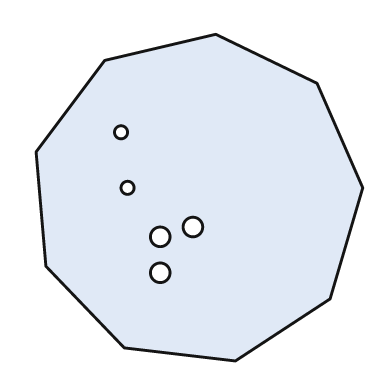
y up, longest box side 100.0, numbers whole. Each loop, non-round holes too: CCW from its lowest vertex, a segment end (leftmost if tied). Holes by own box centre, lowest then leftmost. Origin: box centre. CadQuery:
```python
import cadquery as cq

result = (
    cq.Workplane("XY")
    .moveTo(11.0, -50.0)
    .lineTo(40.0, -31.0)
    .lineTo(50.0, 3.0)
    .lineTo(36.0, 35.0)
    .lineTo(5.0, 50.0)
    .lineTo(-29.0, 42.0)
    .lineTo(-50.0, 14.0)
    .lineTo(-47.0, -21.0)
    .lineTo(-23.0, -46.0)
    .close()
    .moveTo(-12.0, -23.0)
    .circle(3.0)
    .moveTo(-12.0, -12.0)
    .circle(3.0)
    .moveTo(-2.0, -9.0)
    .circle(3.0)
    .moveTo(-22.0, 3.0)
    .circle(2.0)
    .moveTo(-24.0, 20.0)
    .circle(2.0)
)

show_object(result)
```